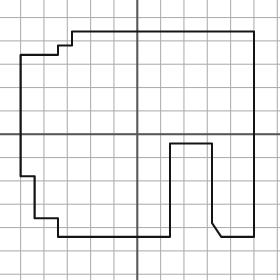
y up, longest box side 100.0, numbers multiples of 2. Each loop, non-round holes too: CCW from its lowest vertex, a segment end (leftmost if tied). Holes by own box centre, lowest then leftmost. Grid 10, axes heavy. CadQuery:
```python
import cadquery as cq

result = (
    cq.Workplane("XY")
    .moveTo(-34.0, -44.0)
    .lineTo(14.0, -44.0)
    .lineTo(14.0, -4.0)
    .lineTo(32.0, -4.0)
    .lineTo(32.0, -38.0)
    .lineTo(36.0, -44.0)
    .lineTo(50.0, -44.0)
    .lineTo(50.0, 44.0)
    .lineTo(-28.0, 44.0)
    .lineTo(-28.0, 38.0)
    .lineTo(-34.0, 38.0)
    .lineTo(-34.0, 34.0)
    .lineTo(-50.0, 34.0)
    .lineTo(-50.0, -18.0)
    .lineTo(-44.0, -18.0)
    .lineTo(-44.0, -36.0)
    .lineTo(-34.0, -36.0)
    .close()
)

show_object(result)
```